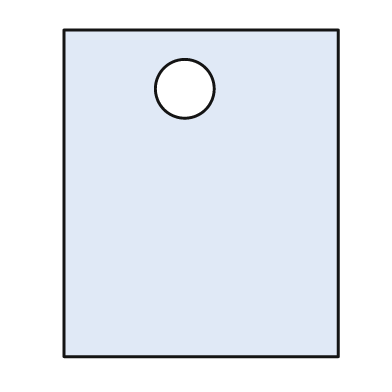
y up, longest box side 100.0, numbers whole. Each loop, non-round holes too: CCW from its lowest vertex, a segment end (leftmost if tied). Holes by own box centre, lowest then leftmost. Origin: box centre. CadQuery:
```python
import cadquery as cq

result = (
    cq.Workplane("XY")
    .moveTo(-42.0, -50.0)
    .lineTo(42.0, -50.0)
    .lineTo(42.0, 50.0)
    .lineTo(-42.0, 50.0)
    .close()
    .moveTo(-5.0, 32.0)
    .circle(9.0)
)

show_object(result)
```